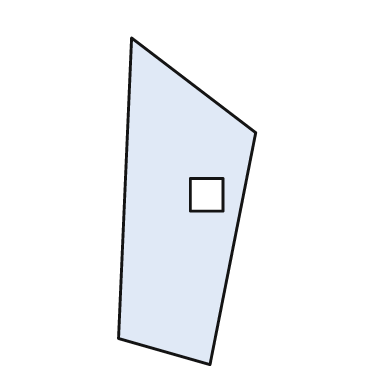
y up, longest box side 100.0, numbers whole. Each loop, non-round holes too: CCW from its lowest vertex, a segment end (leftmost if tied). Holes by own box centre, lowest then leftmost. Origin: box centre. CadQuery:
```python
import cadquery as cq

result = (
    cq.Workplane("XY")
    .moveTo(7.0, -50.0)
    .lineTo(21.0, 21.0)
    .lineTo(-17.0, 50.0)
    .lineTo(-21.0, -42.0)
    .close()
    .moveTo(1.0, -3.0)
    .lineTo(11.0, -3.0)
    .lineTo(11.0, 7.0)
    .lineTo(1.0, 7.0)
    .close()
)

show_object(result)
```